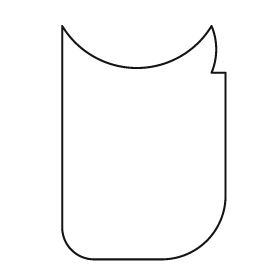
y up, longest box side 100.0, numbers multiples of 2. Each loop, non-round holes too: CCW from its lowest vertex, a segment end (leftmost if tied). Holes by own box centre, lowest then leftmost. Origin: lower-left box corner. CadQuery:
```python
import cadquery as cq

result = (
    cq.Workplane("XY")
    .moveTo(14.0, 0.0)
    .lineTo(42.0, 0.0)
    .threePointArc((62.0, 8.0), (70.0, 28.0))
    .lineTo(70.0, 80.0)
    .lineTo(64.0, 80.0)
    .threePointArc((66.0, 90.0), (64.0, 100.0))
    .threePointArc((32.0, 82.0), (0.0, 100.0))
    .lineTo(0.0, 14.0)
    .threePointArc((4.0, 4.0), (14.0, 0.0))
    .close()
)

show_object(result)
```